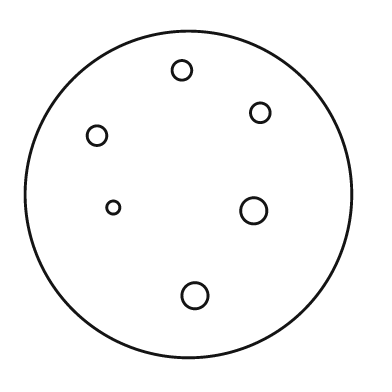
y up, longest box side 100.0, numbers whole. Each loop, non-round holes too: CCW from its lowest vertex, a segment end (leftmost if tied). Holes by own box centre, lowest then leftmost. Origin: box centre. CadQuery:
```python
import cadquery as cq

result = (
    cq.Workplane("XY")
    .moveTo(0.0, 0.0)
    .circle(50.0)
    .moveTo(2.0, -31.0)
    .circle(4.0)
    .moveTo(20.0, -5.0)
    .circle(4.0)
    .moveTo(-23.0, -4.0)
    .circle(2.0)
    .moveTo(-28.0, 18.0)
    .circle(3.0)
    .moveTo(22.0, 25.0)
    .circle(3.0)
    .moveTo(-2.0, 38.0)
    .circle(3.0)
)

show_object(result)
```